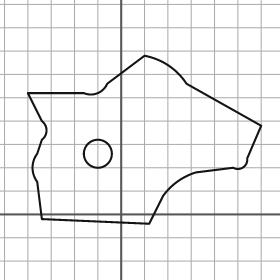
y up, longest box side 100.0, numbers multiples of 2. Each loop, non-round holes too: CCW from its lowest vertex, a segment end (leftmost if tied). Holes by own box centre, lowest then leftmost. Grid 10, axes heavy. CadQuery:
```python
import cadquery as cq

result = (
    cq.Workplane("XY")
    .moveTo(12.0, -4.0)
    .lineTo(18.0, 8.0)
    .threePointArc((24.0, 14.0), (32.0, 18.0))
    .lineTo(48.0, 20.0)
    .threePointArc((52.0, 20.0), (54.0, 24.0))
    .lineTo(60.0, 38.0)
    .lineTo(28.0, 56.0)
    .threePointArc((20.0, 64.0), (10.0, 68.0))
    .lineTo(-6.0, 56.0)
    .threePointArc((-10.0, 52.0), (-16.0, 52.0))
    .lineTo(-40.0, 52.0)
    .lineTo(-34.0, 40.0)
    .threePointArc((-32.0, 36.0), (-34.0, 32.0))
    .lineTo(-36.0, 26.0)
    .threePointArc((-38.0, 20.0), (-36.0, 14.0))
    .lineTo(-34.0, -2.0)
    .close()
    .moveTo(-10.0, 26.0)
    .circle(6.0)
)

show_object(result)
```